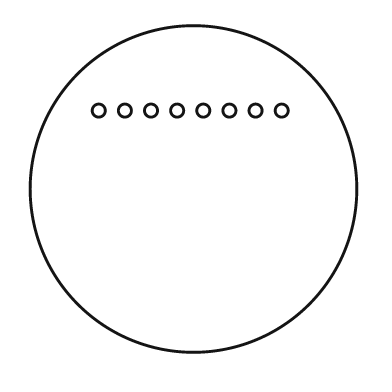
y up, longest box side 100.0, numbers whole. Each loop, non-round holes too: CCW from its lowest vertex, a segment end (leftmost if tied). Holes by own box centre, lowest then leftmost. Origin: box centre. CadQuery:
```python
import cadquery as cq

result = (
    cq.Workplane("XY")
    .moveTo(0.0, 0.0)
    .circle(50.0)
    .moveTo(-29.0, 24.0)
    .circle(2.0)
    .moveTo(-21.0, 24.0)
    .circle(2.0)
    .moveTo(-13.0, 24.0)
    .circle(2.0)
    .moveTo(-5.0, 24.0)
    .circle(2.0)
    .moveTo(3.0, 24.0)
    .circle(2.0)
    .moveTo(11.0, 24.0)
    .circle(2.0)
    .moveTo(19.0, 24.0)
    .circle(2.0)
    .moveTo(27.0, 24.0)
    .circle(2.0)
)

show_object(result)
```